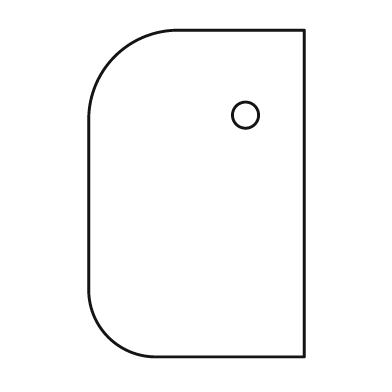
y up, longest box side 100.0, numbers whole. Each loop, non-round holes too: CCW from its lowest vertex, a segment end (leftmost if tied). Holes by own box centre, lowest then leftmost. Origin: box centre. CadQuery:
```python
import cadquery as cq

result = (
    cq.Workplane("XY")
    .moveTo(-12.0, -50.0)
    .lineTo(33.0, -50.0)
    .lineTo(33.0, 50.0)
    .lineTo(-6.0, 50.0)
    .threePointArc((-25.0, 42.0), (-33.0, 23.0))
    .lineTo(-33.0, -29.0)
    .threePointArc((-27.0, -44.0), (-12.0, -50.0))
    .close()
    .moveTo(15.0, 24.0)
    .circle(4.0)
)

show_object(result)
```